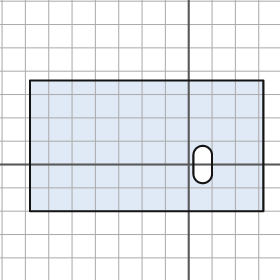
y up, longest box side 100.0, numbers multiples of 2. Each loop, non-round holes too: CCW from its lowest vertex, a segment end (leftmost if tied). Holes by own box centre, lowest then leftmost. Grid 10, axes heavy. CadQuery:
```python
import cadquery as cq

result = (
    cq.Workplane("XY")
    .moveTo(-68.0, -20.0)
    .lineTo(32.0, -20.0)
    .lineTo(32.0, 36.0)
    .lineTo(-68.0, 36.0)
    .close()
    .moveTo(2.0, -4.0)
    .threePointArc((6.0, -8.0), (10.0, -4.0))
    .lineTo(10.0, 4.0)
    .threePointArc((6.0, 8.0), (2.0, 4.0))
    .close()
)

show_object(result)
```